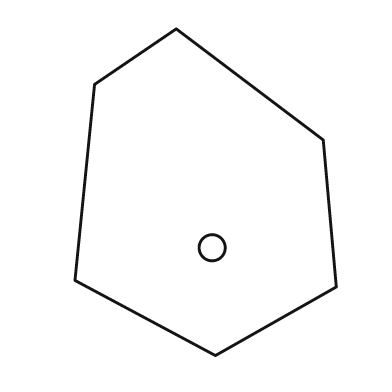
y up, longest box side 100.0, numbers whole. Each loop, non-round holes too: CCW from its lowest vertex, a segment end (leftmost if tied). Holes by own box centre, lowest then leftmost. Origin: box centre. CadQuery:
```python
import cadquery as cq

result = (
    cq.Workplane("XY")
    .moveTo(3.0, -50.0)
    .lineTo(40.0, -29.0)
    .lineTo(36.0, 16.0)
    .lineTo(-9.0, 50.0)
    .lineTo(-34.0, 33.0)
    .lineTo(-40.0, -27.0)
    .close()
    .moveTo(2.0, -17.0)
    .circle(4.0)
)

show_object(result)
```